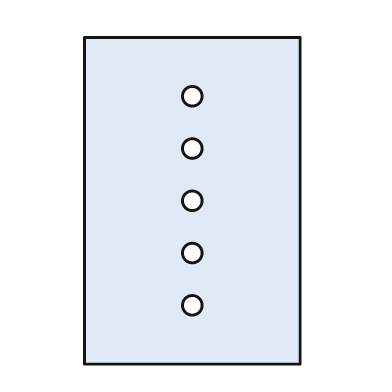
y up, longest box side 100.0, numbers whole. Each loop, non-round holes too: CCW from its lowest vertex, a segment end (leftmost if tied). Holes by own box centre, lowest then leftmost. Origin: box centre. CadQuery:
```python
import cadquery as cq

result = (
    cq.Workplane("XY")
    .moveTo(-33.0, -50.0)
    .lineTo(33.0, -50.0)
    .lineTo(33.0, 50.0)
    .lineTo(-33.0, 50.0)
    .close()
    .moveTo(0.0, -32.0)
    .circle(3.0)
    .moveTo(0.0, -16.0)
    .circle(3.0)
    .moveTo(0.0, 0.0)
    .circle(3.0)
    .moveTo(0.0, 16.0)
    .circle(3.0)
    .moveTo(0.0, 32.0)
    .circle(3.0)
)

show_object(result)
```